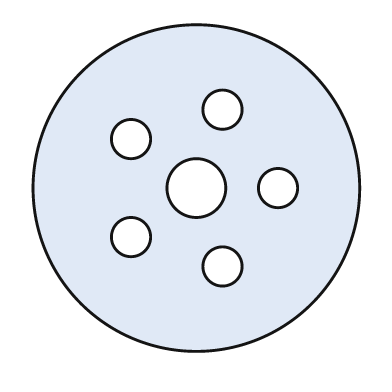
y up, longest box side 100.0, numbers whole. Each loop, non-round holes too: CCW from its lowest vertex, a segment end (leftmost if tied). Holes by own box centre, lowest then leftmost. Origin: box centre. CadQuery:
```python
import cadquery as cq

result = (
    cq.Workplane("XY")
    .moveTo(0.0, 0.0)
    .circle(50.0)
    .moveTo(8.0, -24.0)
    .circle(6.0)
    .moveTo(-20.0, -15.0)
    .circle(6.0)
    .moveTo(0.0, 0.0)
    .circle(9.0)
    .moveTo(25.0, 0.0)
    .circle(6.0)
    .moveTo(-20.0, 15.0)
    .circle(6.0)
    .moveTo(8.0, 24.0)
    .circle(6.0)
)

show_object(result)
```